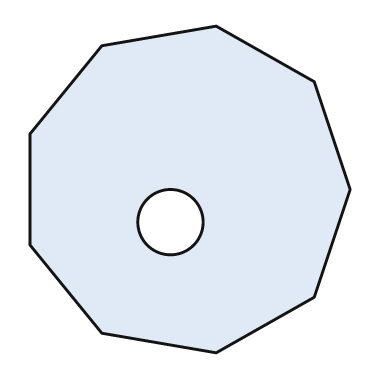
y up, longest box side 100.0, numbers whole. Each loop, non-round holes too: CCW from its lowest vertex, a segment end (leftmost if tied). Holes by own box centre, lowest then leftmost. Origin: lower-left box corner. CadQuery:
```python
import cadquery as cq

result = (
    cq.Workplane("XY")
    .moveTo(57.0, 0.0)
    .lineTo(87.0, 17.0)
    .lineTo(98.0, 50.0)
    .lineTo(87.0, 83.0)
    .lineTo(57.0, 100.0)
    .lineTo(22.0, 94.0)
    .lineTo(0.0, 67.0)
    .lineTo(0.0, 33.0)
    .lineTo(22.0, 6.0)
    .close()
    .moveTo(43.0, 40.0)
    .circle(10.0)
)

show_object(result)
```